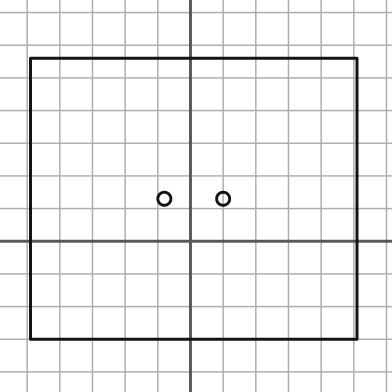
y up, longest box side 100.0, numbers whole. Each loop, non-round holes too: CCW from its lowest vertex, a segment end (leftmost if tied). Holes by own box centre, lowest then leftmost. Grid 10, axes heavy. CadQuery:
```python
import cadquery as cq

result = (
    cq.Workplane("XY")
    .moveTo(-49.0, -30.0)
    .lineTo(51.0, -30.0)
    .lineTo(51.0, 56.0)
    .lineTo(-49.0, 56.0)
    .close()
    .moveTo(-8.0, 13.0)
    .circle(2.0)
    .moveTo(10.0, 13.0)
    .circle(2.0)
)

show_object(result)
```